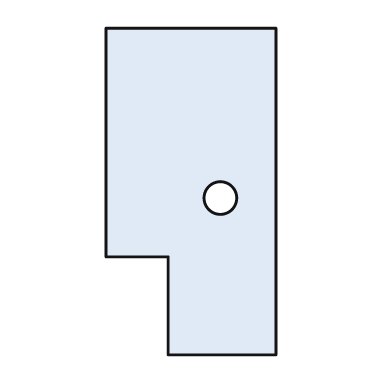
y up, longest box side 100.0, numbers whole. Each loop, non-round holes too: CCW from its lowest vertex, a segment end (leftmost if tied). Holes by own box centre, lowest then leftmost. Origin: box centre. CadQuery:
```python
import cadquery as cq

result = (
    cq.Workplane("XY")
    .moveTo(-7.0, -50.0)
    .lineTo(26.0, -50.0)
    .lineTo(26.0, 50.0)
    .lineTo(-26.0, 50.0)
    .lineTo(-26.0, -20.0)
    .lineTo(-7.0, -20.0)
    .close()
    .moveTo(9.0, -2.0)
    .circle(5.0)
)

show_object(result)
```